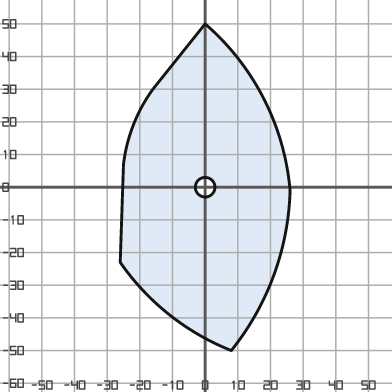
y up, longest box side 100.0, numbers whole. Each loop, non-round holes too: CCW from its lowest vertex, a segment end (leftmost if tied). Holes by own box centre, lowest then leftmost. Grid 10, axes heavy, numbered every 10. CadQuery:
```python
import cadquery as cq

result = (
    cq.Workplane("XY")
    .moveTo(8.0, -50.0)
    .threePointArc((21.0, -27.0), (26.0, -1.0))
    .threePointArc((18.0, 27.0), (0.0, 50.0))
    .lineTo(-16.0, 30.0)
    .threePointArc((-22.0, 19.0), (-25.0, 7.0))
    .lineTo(-26.0, -23.0)
    .threePointArc((-11.0, -39.0), (8.0, -50.0))
    .close()
    .moveTo(0.0, 0.0)
    .circle(3.0)
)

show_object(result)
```